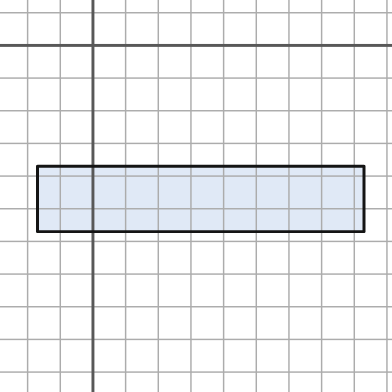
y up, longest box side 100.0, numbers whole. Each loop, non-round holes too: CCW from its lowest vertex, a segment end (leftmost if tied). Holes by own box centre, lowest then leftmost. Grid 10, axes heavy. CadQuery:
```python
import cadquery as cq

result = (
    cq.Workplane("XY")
    .moveTo(-17.0, -57.0)
    .lineTo(83.0, -57.0)
    .lineTo(83.0, -37.0)
    .lineTo(-17.0, -37.0)
    .close()
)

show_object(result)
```